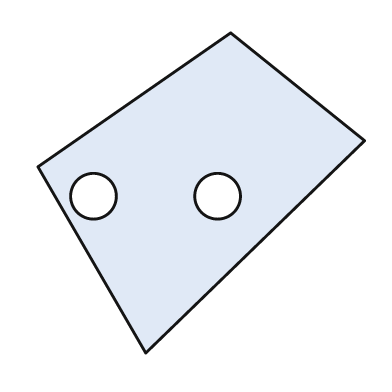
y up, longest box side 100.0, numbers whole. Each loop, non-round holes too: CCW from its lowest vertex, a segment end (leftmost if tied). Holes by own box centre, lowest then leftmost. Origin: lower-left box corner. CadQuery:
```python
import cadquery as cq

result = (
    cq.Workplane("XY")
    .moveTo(33.0, 0.0)
    .lineTo(100.0, 65.0)
    .lineTo(59.0, 98.0)
    .lineTo(0.0, 57.0)
    .close()
    .moveTo(17.0, 48.0)
    .circle(7.0)
    .moveTo(55.0, 48.0)
    .circle(7.0)
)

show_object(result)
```